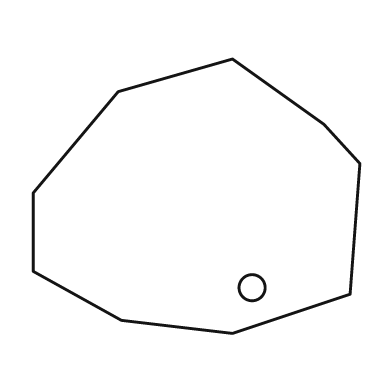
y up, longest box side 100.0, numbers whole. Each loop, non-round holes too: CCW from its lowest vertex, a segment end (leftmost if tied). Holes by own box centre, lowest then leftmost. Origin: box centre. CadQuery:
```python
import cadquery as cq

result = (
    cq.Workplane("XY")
    .moveTo(11.0, -42.0)
    .lineTo(47.0, -30.0)
    .lineTo(50.0, 10.0)
    .lineTo(39.0, 22.0)
    .lineTo(11.0, 42.0)
    .lineTo(-24.0, 32.0)
    .lineTo(-50.0, 1.0)
    .lineTo(-50.0, -23.0)
    .lineTo(-23.0, -38.0)
    .close()
    .moveTo(17.0, -28.0)
    .circle(4.0)
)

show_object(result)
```